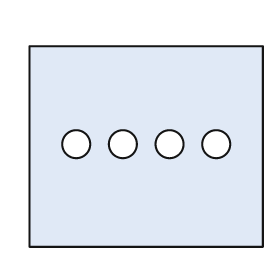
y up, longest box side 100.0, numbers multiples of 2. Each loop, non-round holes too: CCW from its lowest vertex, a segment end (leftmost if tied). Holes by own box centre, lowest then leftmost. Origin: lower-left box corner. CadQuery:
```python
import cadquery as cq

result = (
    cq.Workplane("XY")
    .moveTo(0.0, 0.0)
    .lineTo(100.0, 0.0)
    .lineTo(100.0, 86.0)
    .lineTo(0.0, 86.0)
    .close()
    .moveTo(20.0, 44.0)
    .circle(6.0)
    .moveTo(40.0, 44.0)
    .circle(6.0)
    .moveTo(60.0, 44.0)
    .circle(6.0)
    .moveTo(80.0, 44.0)
    .circle(6.0)
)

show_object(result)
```